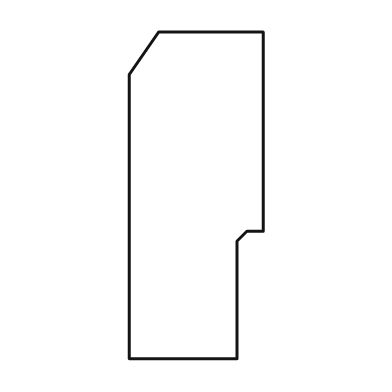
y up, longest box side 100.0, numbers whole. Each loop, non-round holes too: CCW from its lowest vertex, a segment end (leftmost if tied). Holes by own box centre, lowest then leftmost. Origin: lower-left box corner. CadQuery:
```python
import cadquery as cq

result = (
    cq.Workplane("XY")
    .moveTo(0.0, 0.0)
    .lineTo(33.0, 0.0)
    .lineTo(33.0, 36.0)
    .lineTo(36.0, 39.0)
    .lineTo(41.0, 39.0)
    .lineTo(41.0, 100.0)
    .lineTo(9.0, 100.0)
    .lineTo(0.0, 87.0)
    .close()
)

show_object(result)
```